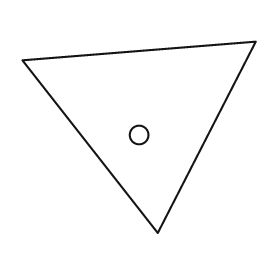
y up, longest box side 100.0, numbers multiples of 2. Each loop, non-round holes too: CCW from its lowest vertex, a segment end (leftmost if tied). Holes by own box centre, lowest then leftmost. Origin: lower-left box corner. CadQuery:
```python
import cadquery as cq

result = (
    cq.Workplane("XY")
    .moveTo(58.0, 0.0)
    .lineTo(100.0, 82.0)
    .lineTo(0.0, 74.0)
    .close()
    .moveTo(50.0, 42.0)
    .circle(4.0)
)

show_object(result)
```